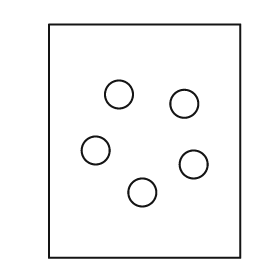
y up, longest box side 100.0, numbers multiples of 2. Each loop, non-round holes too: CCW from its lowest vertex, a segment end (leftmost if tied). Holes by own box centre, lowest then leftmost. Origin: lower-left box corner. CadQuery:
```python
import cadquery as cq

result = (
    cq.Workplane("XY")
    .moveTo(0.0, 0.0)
    .lineTo(82.0, 0.0)
    .lineTo(82.0, 100.0)
    .lineTo(0.0, 100.0)
    .close()
    .moveTo(40.0, 28.0)
    .circle(6.0)
    .moveTo(62.0, 40.0)
    .circle(6.0)
    .moveTo(20.0, 46.0)
    .circle(6.0)
    .moveTo(58.0, 66.0)
    .circle(6.0)
    .moveTo(30.0, 70.0)
    .circle(6.0)
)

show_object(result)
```